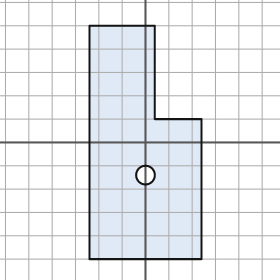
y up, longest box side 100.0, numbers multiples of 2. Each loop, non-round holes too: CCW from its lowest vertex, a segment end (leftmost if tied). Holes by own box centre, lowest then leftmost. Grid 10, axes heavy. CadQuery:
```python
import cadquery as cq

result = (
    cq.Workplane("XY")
    .moveTo(-24.0, -50.0)
    .lineTo(24.0, -50.0)
    .lineTo(24.0, 10.0)
    .lineTo(4.0, 10.0)
    .lineTo(4.0, 50.0)
    .lineTo(-24.0, 50.0)
    .close()
    .moveTo(0.0, -14.0)
    .circle(4.0)
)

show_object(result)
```